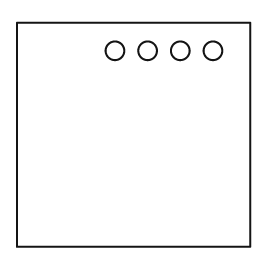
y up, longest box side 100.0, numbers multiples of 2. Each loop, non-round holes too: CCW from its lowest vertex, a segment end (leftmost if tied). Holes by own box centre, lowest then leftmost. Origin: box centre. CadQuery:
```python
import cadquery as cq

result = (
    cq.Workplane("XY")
    .moveTo(-50.0, -48.0)
    .lineTo(50.0, -48.0)
    .lineTo(50.0, 48.0)
    .lineTo(-50.0, 48.0)
    .close()
    .moveTo(-8.0, 36.0)
    .circle(4.0)
    .moveTo(6.0, 36.0)
    .circle(4.0)
    .moveTo(20.0, 36.0)
    .circle(4.0)
    .moveTo(34.0, 36.0)
    .circle(4.0)
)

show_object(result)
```